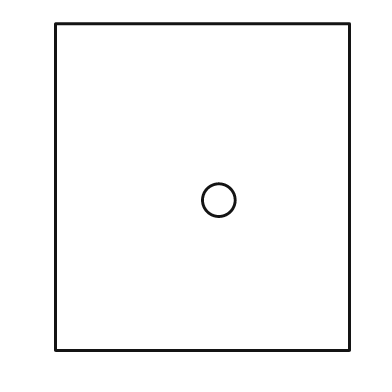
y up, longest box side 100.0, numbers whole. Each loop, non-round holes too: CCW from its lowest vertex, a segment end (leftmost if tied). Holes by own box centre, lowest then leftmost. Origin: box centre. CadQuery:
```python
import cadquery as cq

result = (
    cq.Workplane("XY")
    .moveTo(-45.0, -50.0)
    .lineTo(45.0, -50.0)
    .lineTo(45.0, 50.0)
    .lineTo(-45.0, 50.0)
    .close()
    .moveTo(5.0, -4.0)
    .circle(5.0)
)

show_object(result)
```